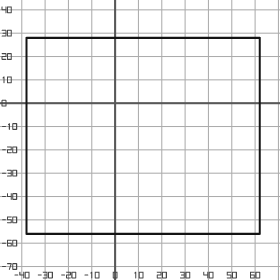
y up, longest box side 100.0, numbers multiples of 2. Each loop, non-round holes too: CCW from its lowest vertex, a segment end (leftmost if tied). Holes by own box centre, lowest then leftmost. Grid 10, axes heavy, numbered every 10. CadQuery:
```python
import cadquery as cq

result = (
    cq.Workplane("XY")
    .moveTo(-38.0, -56.0)
    .lineTo(62.0, -56.0)
    .lineTo(62.0, 28.0)
    .lineTo(-38.0, 28.0)
    .close()
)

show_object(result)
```